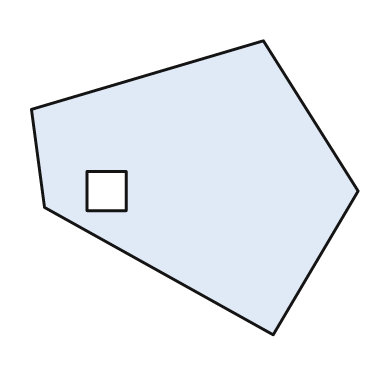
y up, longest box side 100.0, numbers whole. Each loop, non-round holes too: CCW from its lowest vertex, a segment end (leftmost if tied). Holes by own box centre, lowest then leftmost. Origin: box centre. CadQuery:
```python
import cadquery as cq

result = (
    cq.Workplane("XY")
    .moveTo(24.0, -45.0)
    .lineTo(50.0, -1.0)
    .lineTo(21.0, 45.0)
    .lineTo(-50.0, 24.0)
    .lineTo(-46.0, -6.0)
    .close()
    .moveTo(-33.0, -7.0)
    .lineTo(-21.0, -7.0)
    .lineTo(-21.0, 5.0)
    .lineTo(-33.0, 5.0)
    .close()
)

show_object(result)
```